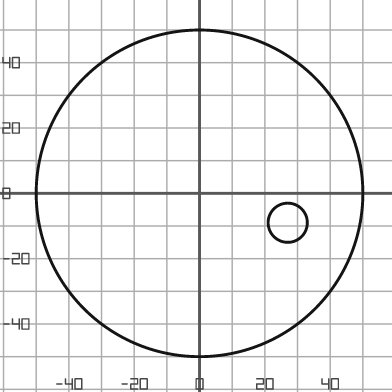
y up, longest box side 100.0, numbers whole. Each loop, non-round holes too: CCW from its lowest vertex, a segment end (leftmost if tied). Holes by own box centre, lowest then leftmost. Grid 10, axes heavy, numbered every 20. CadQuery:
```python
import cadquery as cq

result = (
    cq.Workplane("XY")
    .moveTo(0.0, 0.0)
    .circle(50.0)
    .moveTo(27.0, -9.0)
    .circle(6.0)
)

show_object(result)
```